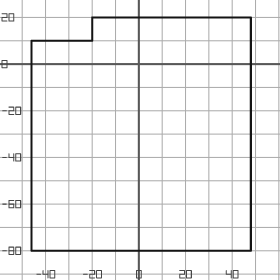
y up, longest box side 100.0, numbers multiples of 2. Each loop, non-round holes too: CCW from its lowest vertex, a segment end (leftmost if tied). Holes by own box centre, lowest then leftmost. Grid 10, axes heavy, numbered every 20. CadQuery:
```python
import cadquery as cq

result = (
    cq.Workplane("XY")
    .moveTo(-46.0, -80.0)
    .lineTo(48.0, -80.0)
    .lineTo(48.0, 20.0)
    .lineTo(-20.0, 20.0)
    .lineTo(-20.0, 10.0)
    .lineTo(-46.0, 10.0)
    .close()
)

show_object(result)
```